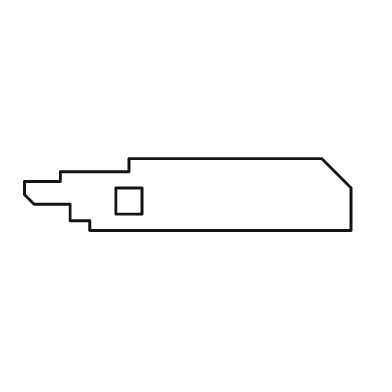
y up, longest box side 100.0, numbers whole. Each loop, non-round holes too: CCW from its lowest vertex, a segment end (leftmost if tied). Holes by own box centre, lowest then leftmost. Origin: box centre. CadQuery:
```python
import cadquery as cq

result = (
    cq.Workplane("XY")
    .moveTo(-30.0, -11.0)
    .lineTo(50.0, -11.0)
    .lineTo(50.0, 2.0)
    .lineTo(41.0, 11.0)
    .lineTo(-18.0, 11.0)
    .lineTo(-18.0, 7.0)
    .lineTo(-39.0, 7.0)
    .lineTo(-39.0, 4.0)
    .lineTo(-50.0, 4.0)
    .lineTo(-50.0, 0.0)
    .lineTo(-47.0, -3.0)
    .lineTo(-36.0, -3.0)
    .lineTo(-36.0, -8.0)
    .lineTo(-30.0, -8.0)
    .close()
    .moveTo(-22.0, -6.0)
    .lineTo(-14.0, -6.0)
    .lineTo(-14.0, 2.0)
    .lineTo(-22.0, 2.0)
    .close()
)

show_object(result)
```